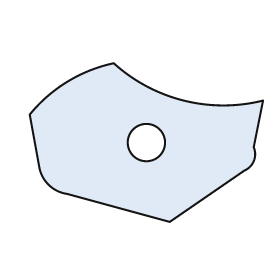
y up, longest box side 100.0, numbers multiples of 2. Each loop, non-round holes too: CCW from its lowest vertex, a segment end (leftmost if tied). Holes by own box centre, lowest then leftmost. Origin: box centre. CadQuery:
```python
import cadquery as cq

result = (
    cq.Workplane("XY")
    .moveTo(10.0, -34.0)
    .lineTo(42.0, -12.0)
    .threePointArc((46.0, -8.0), (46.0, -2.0))
    .lineTo(50.0, 18.0)
    .threePointArc((16.0, 18.0), (-14.0, 34.0))
    .threePointArc((-34.0, 26.0), (-50.0, 12.0))
    .lineTo(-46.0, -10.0)
    .threePointArc((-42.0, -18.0), (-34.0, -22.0))
    .close()
    .moveTo(0.0, 0.0)
    .circle(8.0)
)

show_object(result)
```